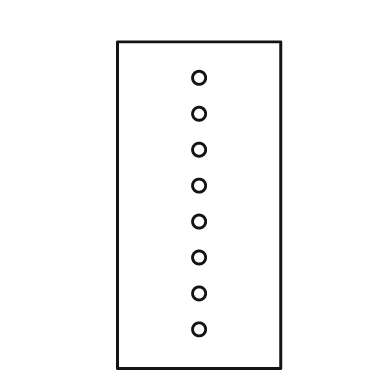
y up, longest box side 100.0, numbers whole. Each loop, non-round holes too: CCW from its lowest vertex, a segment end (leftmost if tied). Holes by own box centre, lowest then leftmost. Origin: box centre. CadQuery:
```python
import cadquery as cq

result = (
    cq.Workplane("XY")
    .moveTo(-25.0, -50.0)
    .lineTo(25.0, -50.0)
    .lineTo(25.0, 50.0)
    .lineTo(-25.0, 50.0)
    .close()
    .moveTo(0.0, -38.0)
    .circle(2.0)
    .moveTo(0.0, -27.0)
    .circle(2.0)
    .moveTo(0.0, -16.0)
    .circle(2.0)
    .moveTo(0.0, -5.0)
    .circle(2.0)
    .moveTo(0.0, 6.0)
    .circle(2.0)
    .moveTo(0.0, 17.0)
    .circle(2.0)
    .moveTo(0.0, 28.0)
    .circle(2.0)
    .moveTo(0.0, 39.0)
    .circle(2.0)
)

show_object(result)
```